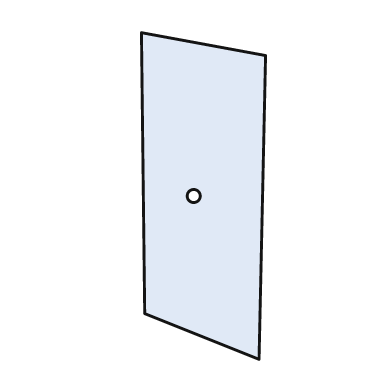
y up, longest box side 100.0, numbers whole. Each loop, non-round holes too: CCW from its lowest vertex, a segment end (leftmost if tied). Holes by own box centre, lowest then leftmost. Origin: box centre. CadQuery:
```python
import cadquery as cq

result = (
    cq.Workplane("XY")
    .moveTo(17.0, -50.0)
    .lineTo(19.0, 43.0)
    .lineTo(-19.0, 50.0)
    .lineTo(-18.0, -36.0)
    .close()
    .moveTo(-3.0, 0.0)
    .circle(2.0)
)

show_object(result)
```